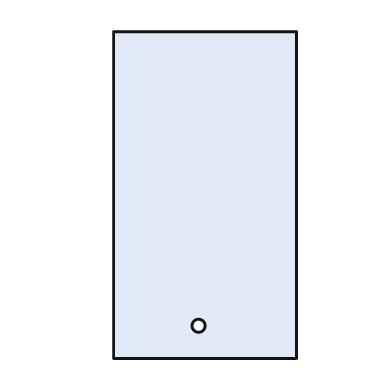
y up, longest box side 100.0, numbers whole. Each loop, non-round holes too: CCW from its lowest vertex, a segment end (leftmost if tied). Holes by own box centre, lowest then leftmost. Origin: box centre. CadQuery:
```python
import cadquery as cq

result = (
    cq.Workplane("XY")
    .moveTo(-28.0, -50.0)
    .lineTo(28.0, -50.0)
    .lineTo(28.0, 50.0)
    .lineTo(-28.0, 50.0)
    .close()
    .moveTo(-2.0, -40.0)
    .circle(2.0)
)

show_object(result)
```